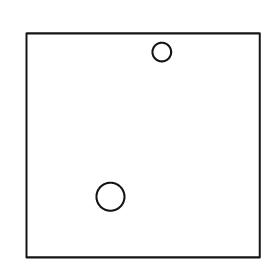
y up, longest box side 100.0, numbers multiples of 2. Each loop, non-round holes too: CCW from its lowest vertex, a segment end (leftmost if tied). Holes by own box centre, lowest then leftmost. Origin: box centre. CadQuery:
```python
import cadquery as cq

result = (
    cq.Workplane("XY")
    .moveTo(-50.0, -48.0)
    .lineTo(50.0, -48.0)
    .lineTo(50.0, 48.0)
    .lineTo(-50.0, 48.0)
    .close()
    .moveTo(-14.0, -22.0)
    .circle(6.0)
    .moveTo(8.0, 40.0)
    .circle(4.0)
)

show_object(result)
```